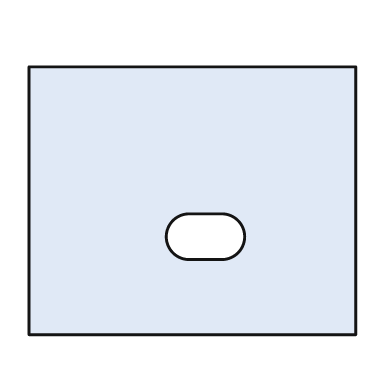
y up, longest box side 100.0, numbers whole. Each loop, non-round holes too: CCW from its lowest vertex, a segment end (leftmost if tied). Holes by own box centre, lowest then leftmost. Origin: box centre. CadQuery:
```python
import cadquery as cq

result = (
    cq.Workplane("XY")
    .moveTo(-50.0, -41.0)
    .lineTo(50.0, -41.0)
    .lineTo(50.0, 41.0)
    .lineTo(-50.0, 41.0)
    .close()
    .moveTo(-1.0, -18.0)
    .lineTo(9.0, -18.0)
    .threePointArc((16.0, -11.0), (9.0, -4.0))
    .lineTo(-1.0, -4.0)
    .threePointArc((-8.0, -11.0), (-1.0, -18.0))
    .close()
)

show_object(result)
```